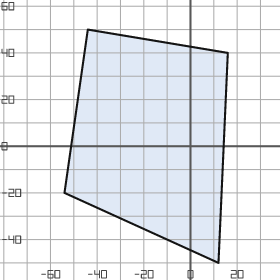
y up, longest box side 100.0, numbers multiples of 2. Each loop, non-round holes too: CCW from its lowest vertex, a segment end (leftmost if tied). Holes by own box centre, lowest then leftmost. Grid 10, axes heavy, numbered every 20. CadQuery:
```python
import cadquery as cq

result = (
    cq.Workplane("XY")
    .moveTo(12.0, -50.0)
    .lineTo(16.0, 40.0)
    .lineTo(-44.0, 50.0)
    .lineTo(-54.0, -20.0)
    .close()
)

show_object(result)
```